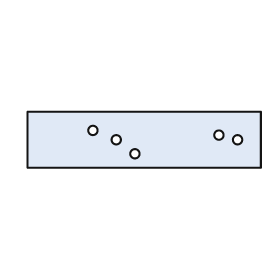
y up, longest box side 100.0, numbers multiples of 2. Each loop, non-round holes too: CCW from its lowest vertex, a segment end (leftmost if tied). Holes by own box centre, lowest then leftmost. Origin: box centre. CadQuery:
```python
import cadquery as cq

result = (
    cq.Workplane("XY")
    .moveTo(-50.0, -12.0)
    .lineTo(50.0, -12.0)
    .lineTo(50.0, 12.0)
    .lineTo(-50.0, 12.0)
    .close()
    .moveTo(-4.0, -6.0)
    .circle(2.0)
    .moveTo(-12.0, 0.0)
    .circle(2.0)
    .moveTo(40.0, 0.0)
    .circle(2.0)
    .moveTo(32.0, 2.0)
    .circle(2.0)
    .moveTo(-22.0, 4.0)
    .circle(2.0)
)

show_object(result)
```